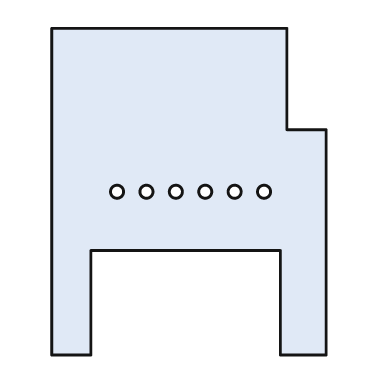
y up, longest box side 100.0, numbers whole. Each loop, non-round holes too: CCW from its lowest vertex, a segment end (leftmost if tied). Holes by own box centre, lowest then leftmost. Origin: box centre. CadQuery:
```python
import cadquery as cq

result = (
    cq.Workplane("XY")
    .moveTo(-42.0, -50.0)
    .lineTo(-30.0, -50.0)
    .lineTo(-30.0, -18.0)
    .lineTo(28.0, -18.0)
    .lineTo(28.0, -50.0)
    .lineTo(42.0, -50.0)
    .lineTo(42.0, 19.0)
    .lineTo(30.0, 19.0)
    .lineTo(30.0, 50.0)
    .lineTo(-42.0, 50.0)
    .close()
    .moveTo(-22.0, 0.0)
    .circle(2.0)
    .moveTo(-13.0, 0.0)
    .circle(2.0)
    .moveTo(-4.0, 0.0)
    .circle(2.0)
    .moveTo(5.0, 0.0)
    .circle(2.0)
    .moveTo(14.0, 0.0)
    .circle(2.0)
    .moveTo(23.0, 0.0)
    .circle(2.0)
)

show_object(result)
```